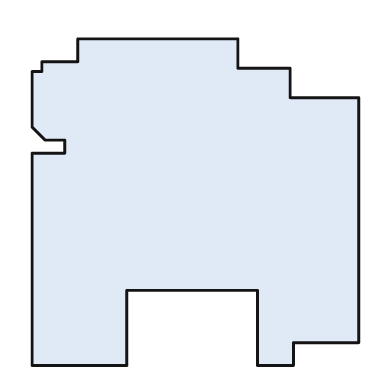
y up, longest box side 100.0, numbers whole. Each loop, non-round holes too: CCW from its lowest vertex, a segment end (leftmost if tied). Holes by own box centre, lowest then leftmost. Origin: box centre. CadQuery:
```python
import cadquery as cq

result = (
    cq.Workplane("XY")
    .moveTo(-50.0, -50.0)
    .lineTo(-21.0, -50.0)
    .lineTo(-21.0, -27.0)
    .lineTo(19.0, -27.0)
    .lineTo(19.0, -50.0)
    .lineTo(30.0, -50.0)
    .lineTo(30.0, -43.0)
    .lineTo(50.0, -43.0)
    .lineTo(50.0, 32.0)
    .lineTo(29.0, 32.0)
    .lineTo(29.0, 41.0)
    .lineTo(13.0, 41.0)
    .lineTo(13.0, 50.0)
    .lineTo(-36.0, 50.0)
    .lineTo(-36.0, 43.0)
    .lineTo(-47.0, 43.0)
    .lineTo(-47.0, 40.0)
    .lineTo(-50.0, 40.0)
    .lineTo(-50.0, 23.0)
    .lineTo(-46.0, 19.0)
    .lineTo(-40.0, 19.0)
    .lineTo(-40.0, 15.0)
    .lineTo(-50.0, 15.0)
    .close()
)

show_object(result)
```